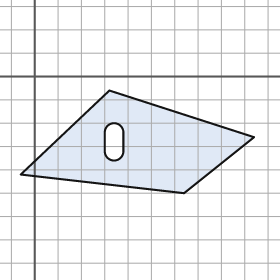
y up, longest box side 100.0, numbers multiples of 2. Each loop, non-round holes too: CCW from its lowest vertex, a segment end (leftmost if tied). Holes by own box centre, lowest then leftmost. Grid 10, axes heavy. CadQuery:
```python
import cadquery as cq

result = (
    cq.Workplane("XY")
    .moveTo(64.0, -50.0)
    .lineTo(94.0, -26.0)
    .lineTo(32.0, -6.0)
    .lineTo(-6.0, -42.0)
    .close()
    .moveTo(30.0, -32.0)
    .threePointArc((34.0, -36.0), (38.0, -32.0))
    .lineTo(38.0, -24.0)
    .threePointArc((34.0, -20.0), (30.0, -24.0))
    .close()
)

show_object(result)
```